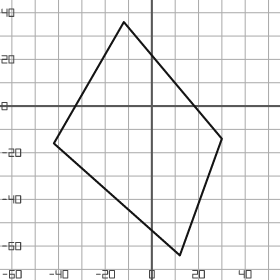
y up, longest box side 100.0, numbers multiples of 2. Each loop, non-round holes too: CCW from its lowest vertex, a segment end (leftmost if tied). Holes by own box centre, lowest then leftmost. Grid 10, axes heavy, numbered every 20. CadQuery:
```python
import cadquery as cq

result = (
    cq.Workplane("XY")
    .moveTo(12.0, -64.0)
    .lineTo(30.0, -14.0)
    .lineTo(-12.0, 36.0)
    .lineTo(-42.0, -16.0)
    .close()
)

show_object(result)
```